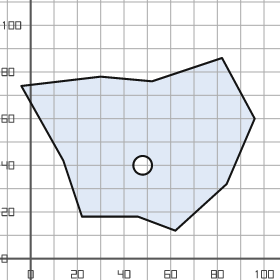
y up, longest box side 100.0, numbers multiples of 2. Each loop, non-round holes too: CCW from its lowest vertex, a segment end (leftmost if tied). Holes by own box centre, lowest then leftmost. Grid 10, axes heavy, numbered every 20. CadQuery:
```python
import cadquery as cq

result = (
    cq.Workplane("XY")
    .moveTo(62.0, 12.0)
    .lineTo(84.0, 32.0)
    .lineTo(96.0, 60.0)
    .lineTo(82.0, 86.0)
    .lineTo(52.0, 76.0)
    .lineTo(30.0, 78.0)
    .lineTo(-4.0, 74.0)
    .lineTo(14.0, 42.0)
    .lineTo(22.0, 18.0)
    .lineTo(46.0, 18.0)
    .close()
    .moveTo(48.0, 40.0)
    .circle(4.0)
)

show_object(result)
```